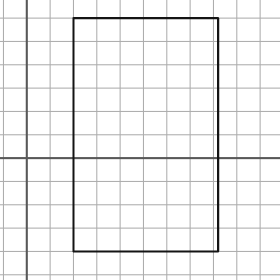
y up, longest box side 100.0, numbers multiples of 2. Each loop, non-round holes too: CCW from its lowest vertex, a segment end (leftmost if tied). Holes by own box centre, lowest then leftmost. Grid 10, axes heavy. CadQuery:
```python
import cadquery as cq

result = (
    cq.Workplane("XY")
    .moveTo(20.0, -40.0)
    .lineTo(82.0, -40.0)
    .lineTo(82.0, 60.0)
    .lineTo(20.0, 60.0)
    .close()
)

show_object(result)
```